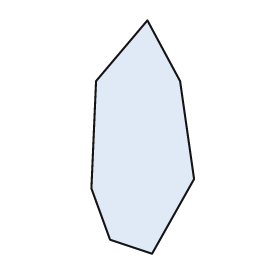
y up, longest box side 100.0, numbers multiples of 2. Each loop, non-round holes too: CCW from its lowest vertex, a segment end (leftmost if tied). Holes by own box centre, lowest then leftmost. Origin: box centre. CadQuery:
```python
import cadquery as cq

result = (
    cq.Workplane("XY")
    .moveTo(4.0, -50.0)
    .lineTo(22.0, -18.0)
    .lineTo(16.0, 24.0)
    .lineTo(2.0, 50.0)
    .lineTo(-20.0, 24.0)
    .lineTo(-22.0, -22.0)
    .lineTo(-14.0, -44.0)
    .close()
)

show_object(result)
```